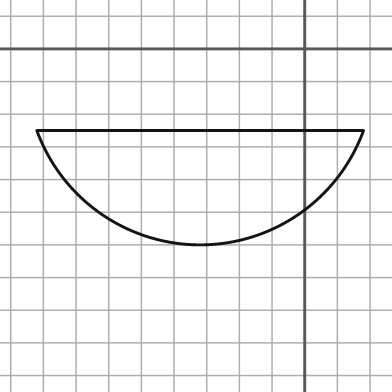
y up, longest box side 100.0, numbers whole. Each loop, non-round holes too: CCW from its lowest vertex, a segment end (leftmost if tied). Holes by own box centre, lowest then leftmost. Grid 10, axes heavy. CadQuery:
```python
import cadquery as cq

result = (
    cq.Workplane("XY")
    .moveTo(-82.0, -25.0)
    .threePointArc((-32.0, -60.0), (18.0, -25.0))
    .close()
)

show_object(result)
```